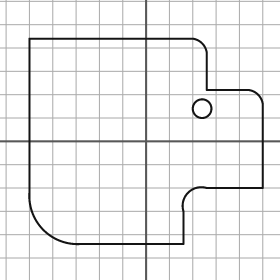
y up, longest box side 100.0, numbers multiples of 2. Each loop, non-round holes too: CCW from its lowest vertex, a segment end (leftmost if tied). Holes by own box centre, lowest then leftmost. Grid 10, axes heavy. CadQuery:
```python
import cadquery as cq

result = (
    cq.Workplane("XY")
    .moveTo(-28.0, -44.0)
    .lineTo(16.0, -44.0)
    .lineTo(16.0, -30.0)
    .threePointArc((18.0, -22.0), (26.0, -20.0))
    .lineTo(50.0, -20.0)
    .lineTo(50.0, 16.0)
    .threePointArc((48.0, 20.0), (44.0, 22.0))
    .lineTo(26.0, 22.0)
    .lineTo(26.0, 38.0)
    .threePointArc((24.0, 42.0), (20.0, 44.0))
    .lineTo(-50.0, 44.0)
    .lineTo(-50.0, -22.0)
    .threePointArc((-44.0, -38.0), (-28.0, -44.0))
    .close()
    .moveTo(24.0, 14.0)
    .circle(4.0)
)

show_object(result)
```